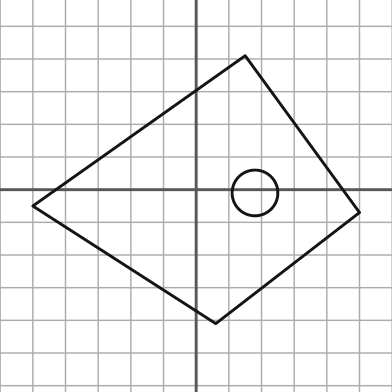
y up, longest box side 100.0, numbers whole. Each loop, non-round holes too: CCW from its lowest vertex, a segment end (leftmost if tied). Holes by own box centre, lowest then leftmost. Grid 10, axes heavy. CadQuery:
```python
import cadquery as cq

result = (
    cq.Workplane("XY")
    .moveTo(6.0, -41.0)
    .lineTo(50.0, -7.0)
    .lineTo(15.0, 41.0)
    .lineTo(-50.0, -5.0)
    .close()
    .moveTo(18.0, -1.0)
    .circle(7.0)
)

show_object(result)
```